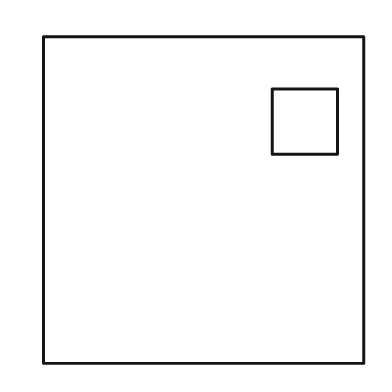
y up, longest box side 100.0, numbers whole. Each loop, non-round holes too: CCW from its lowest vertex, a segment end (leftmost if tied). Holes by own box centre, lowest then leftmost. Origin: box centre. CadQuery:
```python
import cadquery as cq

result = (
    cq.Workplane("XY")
    .moveTo(-49.0, -50.0)
    .lineTo(49.0, -50.0)
    .lineTo(49.0, 50.0)
    .lineTo(-49.0, 50.0)
    .close()
    .moveTo(21.0, 14.0)
    .lineTo(41.0, 14.0)
    .lineTo(41.0, 34.0)
    .lineTo(21.0, 34.0)
    .close()
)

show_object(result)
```